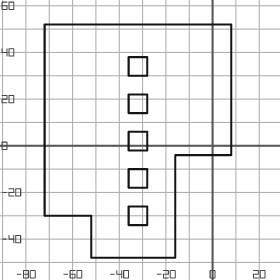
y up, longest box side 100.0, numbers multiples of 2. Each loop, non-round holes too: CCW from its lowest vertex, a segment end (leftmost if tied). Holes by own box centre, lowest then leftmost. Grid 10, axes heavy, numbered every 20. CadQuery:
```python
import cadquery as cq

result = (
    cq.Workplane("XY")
    .moveTo(-52.0, -48.0)
    .lineTo(-16.0, -48.0)
    .lineTo(-16.0, -4.0)
    .lineTo(8.0, -4.0)
    .lineTo(8.0, 52.0)
    .lineTo(-72.0, 52.0)
    .lineTo(-72.0, -30.0)
    .lineTo(-52.0, -30.0)
    .close()
    .moveTo(-36.0, -34.0)
    .lineTo(-28.0, -34.0)
    .lineTo(-28.0, -26.0)
    .lineTo(-36.0, -26.0)
    .close()
    .moveTo(-36.0, -18.0)
    .lineTo(-28.0, -18.0)
    .lineTo(-28.0, -10.0)
    .lineTo(-36.0, -10.0)
    .close()
    .moveTo(-36.0, -2.0)
    .lineTo(-28.0, -2.0)
    .lineTo(-28.0, 6.0)
    .lineTo(-36.0, 6.0)
    .close()
    .moveTo(-36.0, 14.0)
    .lineTo(-28.0, 14.0)
    .lineTo(-28.0, 22.0)
    .lineTo(-36.0, 22.0)
    .close()
    .moveTo(-36.0, 30.0)
    .lineTo(-28.0, 30.0)
    .lineTo(-28.0, 38.0)
    .lineTo(-36.0, 38.0)
    .close()
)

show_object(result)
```